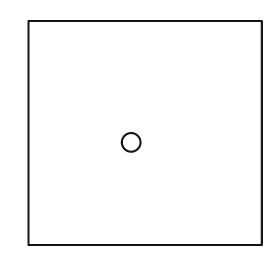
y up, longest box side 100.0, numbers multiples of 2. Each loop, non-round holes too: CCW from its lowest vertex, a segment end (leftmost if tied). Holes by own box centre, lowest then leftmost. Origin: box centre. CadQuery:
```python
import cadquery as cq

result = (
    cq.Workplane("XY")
    .moveTo(-50.0, -48.0)
    .lineTo(50.0, -48.0)
    .lineTo(50.0, 48.0)
    .lineTo(-50.0, 48.0)
    .close()
    .moveTo(-6.0, -4.0)
    .circle(4.0)
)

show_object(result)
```